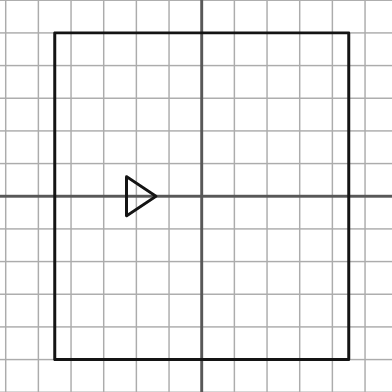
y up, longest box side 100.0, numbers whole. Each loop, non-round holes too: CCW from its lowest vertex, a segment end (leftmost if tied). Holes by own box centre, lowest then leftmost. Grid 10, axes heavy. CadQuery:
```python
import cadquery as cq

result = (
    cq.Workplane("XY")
    .moveTo(-45.0, -50.0)
    .lineTo(45.0, -50.0)
    .lineTo(45.0, 50.0)
    .lineTo(-45.0, 50.0)
    .close()
    .moveTo(-23.0, -6.0)
    .lineTo(-14.0, 0.0)
    .lineTo(-23.0, 6.0)
    .close()
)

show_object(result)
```